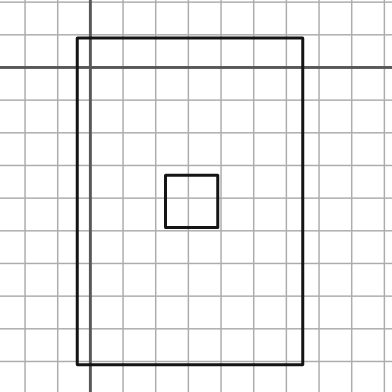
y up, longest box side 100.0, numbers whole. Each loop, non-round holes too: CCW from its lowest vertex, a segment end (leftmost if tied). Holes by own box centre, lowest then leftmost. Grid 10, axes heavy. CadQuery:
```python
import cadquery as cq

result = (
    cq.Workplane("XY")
    .moveTo(-4.0, -91.0)
    .lineTo(65.0, -91.0)
    .lineTo(65.0, 9.0)
    .lineTo(-4.0, 9.0)
    .close()
    .moveTo(23.0, -49.0)
    .lineTo(39.0, -49.0)
    .lineTo(39.0, -33.0)
    .lineTo(23.0, -33.0)
    .close()
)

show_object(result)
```